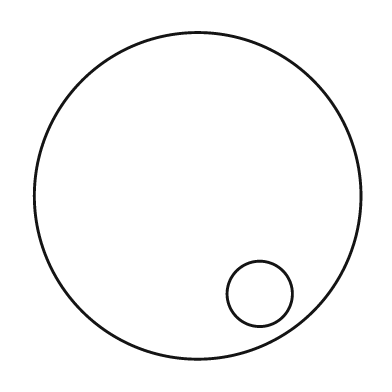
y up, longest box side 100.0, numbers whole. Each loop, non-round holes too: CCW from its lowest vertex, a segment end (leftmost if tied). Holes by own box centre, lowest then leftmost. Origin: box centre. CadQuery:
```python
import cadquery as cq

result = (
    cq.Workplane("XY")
    .moveTo(0.0, 0.0)
    .circle(50.0)
    .moveTo(19.0, -30.0)
    .circle(10.0)
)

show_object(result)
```